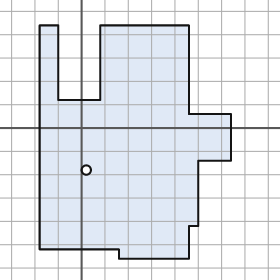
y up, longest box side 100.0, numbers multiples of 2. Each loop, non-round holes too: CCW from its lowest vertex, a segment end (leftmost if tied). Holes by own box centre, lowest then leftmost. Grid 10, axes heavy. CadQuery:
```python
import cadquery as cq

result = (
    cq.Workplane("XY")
    .moveTo(16.0, -56.0)
    .lineTo(46.0, -56.0)
    .lineTo(46.0, -42.0)
    .lineTo(50.0, -42.0)
    .lineTo(50.0, -14.0)
    .lineTo(64.0, -14.0)
    .lineTo(64.0, 6.0)
    .lineTo(46.0, 6.0)
    .lineTo(46.0, 44.0)
    .lineTo(8.0, 44.0)
    .lineTo(8.0, 12.0)
    .lineTo(-10.0, 12.0)
    .lineTo(-10.0, 44.0)
    .lineTo(-18.0, 44.0)
    .lineTo(-18.0, -52.0)
    .lineTo(16.0, -52.0)
    .close()
    .moveTo(2.0, -18.0)
    .circle(2.0)
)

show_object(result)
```